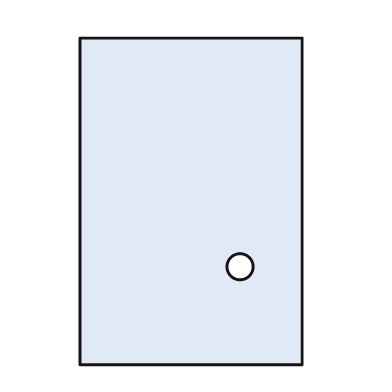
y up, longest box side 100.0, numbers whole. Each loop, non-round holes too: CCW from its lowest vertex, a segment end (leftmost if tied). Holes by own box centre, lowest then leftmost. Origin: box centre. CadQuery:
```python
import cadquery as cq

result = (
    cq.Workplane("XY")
    .moveTo(-34.0, -50.0)
    .lineTo(34.0, -50.0)
    .lineTo(34.0, 50.0)
    .lineTo(-34.0, 50.0)
    .close()
    .moveTo(15.0, -20.0)
    .circle(4.0)
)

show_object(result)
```